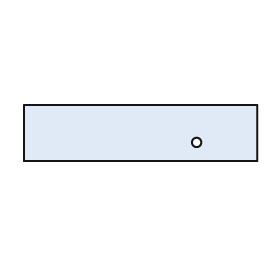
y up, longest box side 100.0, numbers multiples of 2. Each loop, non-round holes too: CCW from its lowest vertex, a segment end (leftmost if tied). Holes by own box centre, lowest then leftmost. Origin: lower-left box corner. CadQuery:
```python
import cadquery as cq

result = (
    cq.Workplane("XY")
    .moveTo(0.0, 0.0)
    .lineTo(100.0, 0.0)
    .lineTo(100.0, 24.0)
    .lineTo(0.0, 24.0)
    .close()
    .moveTo(74.0, 8.0)
    .circle(2.0)
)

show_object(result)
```